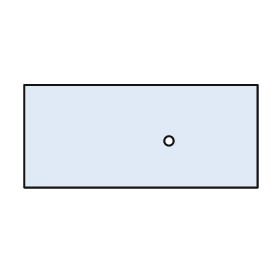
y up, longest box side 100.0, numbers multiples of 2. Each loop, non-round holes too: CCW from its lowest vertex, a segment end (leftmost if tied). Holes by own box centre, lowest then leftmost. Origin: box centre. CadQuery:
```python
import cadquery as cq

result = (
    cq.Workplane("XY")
    .moveTo(-50.0, -22.0)
    .lineTo(50.0, -22.0)
    .lineTo(50.0, 22.0)
    .lineTo(-50.0, 22.0)
    .close()
    .moveTo(12.0, -2.0)
    .circle(2.0)
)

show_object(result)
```